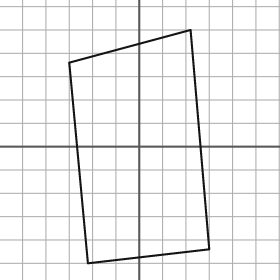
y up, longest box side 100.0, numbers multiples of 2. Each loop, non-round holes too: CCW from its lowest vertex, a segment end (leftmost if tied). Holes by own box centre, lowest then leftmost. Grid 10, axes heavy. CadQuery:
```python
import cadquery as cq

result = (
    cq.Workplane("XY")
    .moveTo(-22.0, -50.0)
    .lineTo(30.0, -44.0)
    .lineTo(22.0, 50.0)
    .lineTo(-30.0, 36.0)
    .close()
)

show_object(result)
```